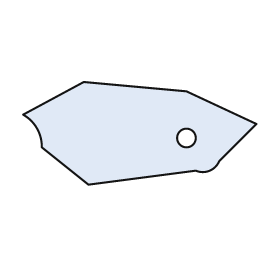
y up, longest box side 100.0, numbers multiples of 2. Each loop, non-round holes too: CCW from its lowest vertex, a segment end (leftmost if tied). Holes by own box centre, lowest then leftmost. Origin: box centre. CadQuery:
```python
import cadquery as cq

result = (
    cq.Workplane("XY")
    .moveTo(-22.0, -22.0)
    .lineTo(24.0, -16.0)
    .threePointArc((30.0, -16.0), (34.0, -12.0))
    .lineTo(50.0, 4.0)
    .lineTo(20.0, 18.0)
    .lineTo(-24.0, 22.0)
    .lineTo(-50.0, 8.0)
    .threePointArc((-44.0, 2.0), (-42.0, -6.0))
    .close()
    .moveTo(20.0, -2.0)
    .circle(4.0)
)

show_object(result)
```